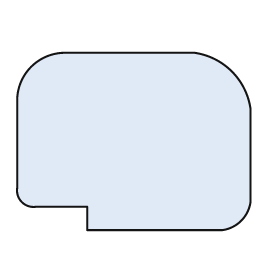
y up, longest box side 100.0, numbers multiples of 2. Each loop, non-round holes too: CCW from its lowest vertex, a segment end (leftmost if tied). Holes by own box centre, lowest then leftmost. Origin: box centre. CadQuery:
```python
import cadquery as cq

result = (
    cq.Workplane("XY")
    .moveTo(-20.0, -38.0)
    .lineTo(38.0, -38.0)
    .threePointArc((46.0, -34.0), (50.0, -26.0))
    .lineTo(50.0, 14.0)
    .threePointArc((42.0, 30.0), (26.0, 38.0))
    .lineTo(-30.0, 38.0)
    .threePointArc((-44.0, 32.0), (-50.0, 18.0))
    .lineTo(-50.0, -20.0)
    .threePointArc((-48.0, -26.0), (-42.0, -28.0))
    .lineTo(-20.0, -28.0)
    .close()
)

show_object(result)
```